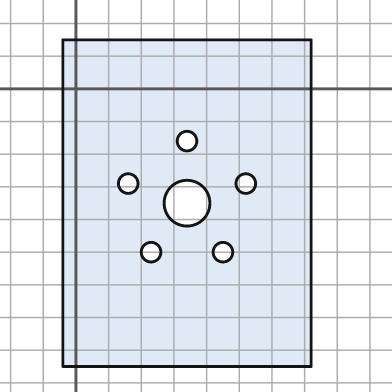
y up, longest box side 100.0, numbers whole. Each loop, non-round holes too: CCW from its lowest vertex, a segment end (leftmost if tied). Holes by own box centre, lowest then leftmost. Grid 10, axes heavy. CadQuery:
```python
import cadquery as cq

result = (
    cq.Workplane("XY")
    .moveTo(-4.0, -85.0)
    .lineTo(72.0, -85.0)
    .lineTo(72.0, 15.0)
    .lineTo(-4.0, 15.0)
    .close()
    .moveTo(23.0, -50.0)
    .circle(3.0)
    .moveTo(45.0, -50.0)
    .circle(3.0)
    .moveTo(34.0, -35.0)
    .circle(7.0)
    .moveTo(16.0, -29.0)
    .circle(3.0)
    .moveTo(52.0, -29.0)
    .circle(3.0)
    .moveTo(34.0, -16.0)
    .circle(3.0)
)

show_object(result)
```